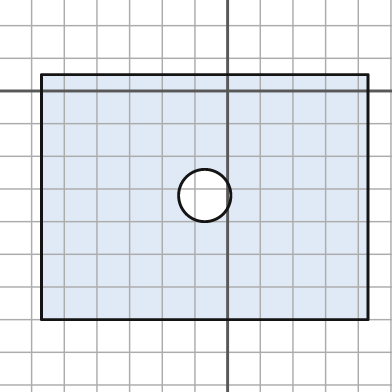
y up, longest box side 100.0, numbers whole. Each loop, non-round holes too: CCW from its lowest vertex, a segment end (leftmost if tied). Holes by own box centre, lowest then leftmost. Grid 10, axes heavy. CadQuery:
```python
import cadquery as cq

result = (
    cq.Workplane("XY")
    .moveTo(-57.0, -70.0)
    .lineTo(43.0, -70.0)
    .lineTo(43.0, 5.0)
    .lineTo(-57.0, 5.0)
    .close()
    .moveTo(-7.0, -32.0)
    .circle(8.0)
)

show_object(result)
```